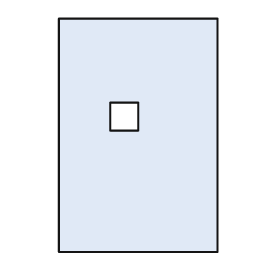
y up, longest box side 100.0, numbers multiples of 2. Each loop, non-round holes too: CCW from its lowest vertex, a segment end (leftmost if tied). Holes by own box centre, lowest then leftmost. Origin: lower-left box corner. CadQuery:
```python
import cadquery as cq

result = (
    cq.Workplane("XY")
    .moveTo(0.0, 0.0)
    .lineTo(68.0, 0.0)
    .lineTo(68.0, 100.0)
    .lineTo(0.0, 100.0)
    .close()
    .moveTo(22.0, 52.0)
    .lineTo(34.0, 52.0)
    .lineTo(34.0, 64.0)
    .lineTo(22.0, 64.0)
    .close()
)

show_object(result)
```